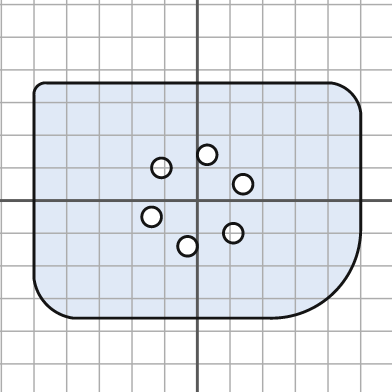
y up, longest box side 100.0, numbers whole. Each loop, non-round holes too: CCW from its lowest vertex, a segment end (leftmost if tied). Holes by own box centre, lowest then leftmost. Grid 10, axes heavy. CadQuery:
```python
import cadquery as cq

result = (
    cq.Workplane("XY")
    .moveTo(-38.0, -36.0)
    .lineTo(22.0, -36.0)
    .threePointArc((42.0, -28.0), (50.0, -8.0))
    .lineTo(50.0, 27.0)
    .threePointArc((47.0, 33.0), (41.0, 36.0))
    .lineTo(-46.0, 36.0)
    .threePointArc((-49.0, 35.0), (-50.0, 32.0))
    .lineTo(-50.0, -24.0)
    .threePointArc((-46.0, -32.0), (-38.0, -36.0))
    .close()
    .moveTo(-3.0, -14.0)
    .circle(3.0)
    .moveTo(11.0, -10.0)
    .circle(3.0)
    .moveTo(-14.0, -5.0)
    .circle(3.0)
    .moveTo(14.0, 5.0)
    .circle(3.0)
    .moveTo(-11.0, 10.0)
    .circle(3.0)
    .moveTo(3.0, 14.0)
    .circle(3.0)
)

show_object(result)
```